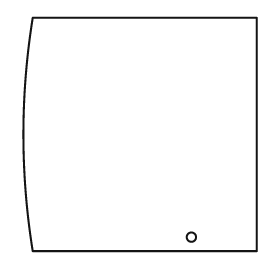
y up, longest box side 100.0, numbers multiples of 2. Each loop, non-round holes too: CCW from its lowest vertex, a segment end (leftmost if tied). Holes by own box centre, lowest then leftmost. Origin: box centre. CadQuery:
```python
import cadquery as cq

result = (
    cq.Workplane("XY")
    .moveTo(-46.0, -50.0)
    .lineTo(50.0, -50.0)
    .lineTo(50.0, 50.0)
    .lineTo(-46.0, 50.0)
    .threePointArc((-50.0, 0.0), (-46.0, -50.0))
    .close()
    .moveTo(22.0, -44.0)
    .circle(2.0)
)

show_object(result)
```